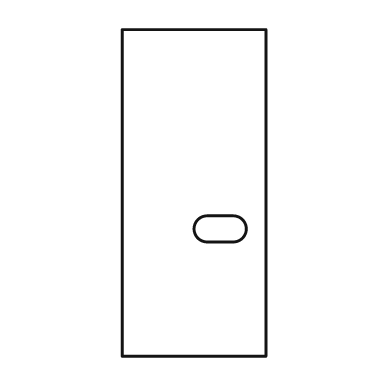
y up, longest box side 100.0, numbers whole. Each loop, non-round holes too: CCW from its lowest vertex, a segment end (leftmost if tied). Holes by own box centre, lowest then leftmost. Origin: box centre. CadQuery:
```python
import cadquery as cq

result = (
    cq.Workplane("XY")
    .moveTo(-22.0, -50.0)
    .lineTo(22.0, -50.0)
    .lineTo(22.0, 50.0)
    .lineTo(-22.0, 50.0)
    .close()
    .moveTo(4.0, -15.0)
    .lineTo(12.0, -15.0)
    .threePointArc((16.0, -11.0), (12.0, -7.0))
    .lineTo(4.0, -7.0)
    .threePointArc((0.0, -11.0), (4.0, -15.0))
    .close()
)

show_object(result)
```